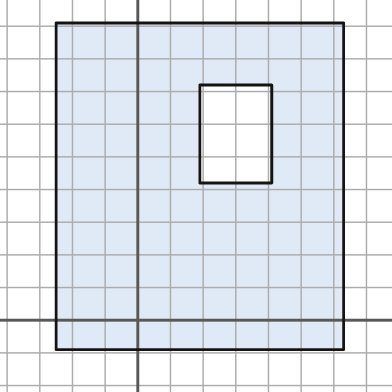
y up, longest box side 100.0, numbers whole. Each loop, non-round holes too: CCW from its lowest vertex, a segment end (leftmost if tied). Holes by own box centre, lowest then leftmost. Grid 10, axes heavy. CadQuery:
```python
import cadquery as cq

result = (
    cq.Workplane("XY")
    .moveTo(-25.0, -9.0)
    .lineTo(63.0, -9.0)
    .lineTo(63.0, 91.0)
    .lineTo(-25.0, 91.0)
    .close()
    .moveTo(19.0, 42.0)
    .lineTo(41.0, 42.0)
    .lineTo(41.0, 72.0)
    .lineTo(19.0, 72.0)
    .close()
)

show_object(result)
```